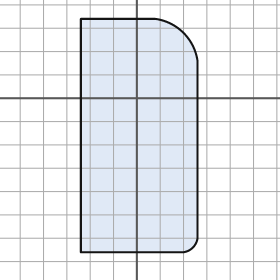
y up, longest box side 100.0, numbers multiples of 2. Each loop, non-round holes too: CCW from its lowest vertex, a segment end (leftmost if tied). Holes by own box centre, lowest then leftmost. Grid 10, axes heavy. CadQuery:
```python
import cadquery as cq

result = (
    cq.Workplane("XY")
    .moveTo(-24.0, -66.0)
    .lineTo(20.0, -66.0)
    .threePointArc((24.0, -64.0), (26.0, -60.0))
    .lineTo(26.0, 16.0)
    .threePointArc((20.0, 28.0), (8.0, 34.0))
    .lineTo(-24.0, 34.0)
    .close()
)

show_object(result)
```